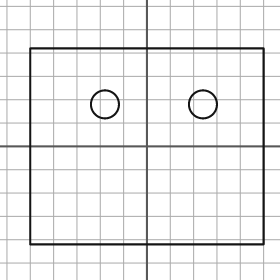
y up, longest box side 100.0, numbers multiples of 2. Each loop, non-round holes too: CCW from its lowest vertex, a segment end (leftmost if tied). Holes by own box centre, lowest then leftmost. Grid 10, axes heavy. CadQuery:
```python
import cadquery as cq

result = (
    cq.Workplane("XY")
    .moveTo(-50.0, -42.0)
    .lineTo(50.0, -42.0)
    .lineTo(50.0, 42.0)
    .lineTo(-50.0, 42.0)
    .close()
    .moveTo(-18.0, 18.0)
    .circle(6.0)
    .moveTo(24.0, 18.0)
    .circle(6.0)
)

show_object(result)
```